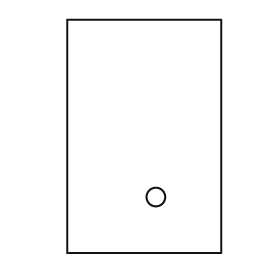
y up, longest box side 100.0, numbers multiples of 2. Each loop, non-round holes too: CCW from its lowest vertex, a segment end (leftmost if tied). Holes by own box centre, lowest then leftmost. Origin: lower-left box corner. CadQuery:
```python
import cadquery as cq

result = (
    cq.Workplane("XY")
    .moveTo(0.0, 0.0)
    .lineTo(66.0, 0.0)
    .lineTo(66.0, 100.0)
    .lineTo(0.0, 100.0)
    .close()
    .moveTo(38.0, 24.0)
    .circle(4.0)
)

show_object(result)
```